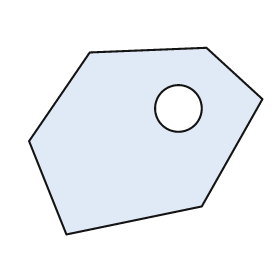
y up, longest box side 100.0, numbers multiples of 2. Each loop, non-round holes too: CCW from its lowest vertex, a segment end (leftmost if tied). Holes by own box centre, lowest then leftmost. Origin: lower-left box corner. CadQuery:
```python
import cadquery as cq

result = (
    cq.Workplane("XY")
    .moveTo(16.0, 0.0)
    .lineTo(74.0, 12.0)
    .lineTo(100.0, 58.0)
    .lineTo(76.0, 80.0)
    .lineTo(26.0, 78.0)
    .lineTo(0.0, 40.0)
    .close()
    .moveTo(64.0, 54.0)
    .circle(10.0)
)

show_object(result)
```